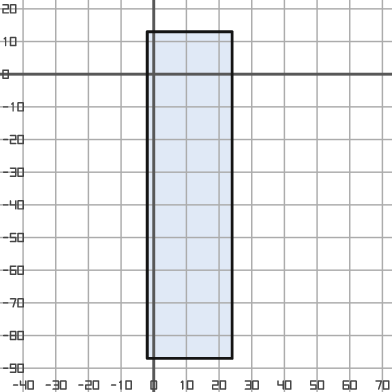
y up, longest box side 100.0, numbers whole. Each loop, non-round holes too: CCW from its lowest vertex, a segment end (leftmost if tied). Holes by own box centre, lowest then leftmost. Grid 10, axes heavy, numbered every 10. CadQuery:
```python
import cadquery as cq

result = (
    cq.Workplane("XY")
    .moveTo(-2.0, -87.0)
    .lineTo(24.0, -87.0)
    .lineTo(24.0, 13.0)
    .lineTo(-2.0, 13.0)
    .close()
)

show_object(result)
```